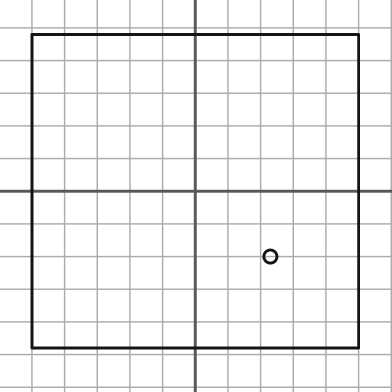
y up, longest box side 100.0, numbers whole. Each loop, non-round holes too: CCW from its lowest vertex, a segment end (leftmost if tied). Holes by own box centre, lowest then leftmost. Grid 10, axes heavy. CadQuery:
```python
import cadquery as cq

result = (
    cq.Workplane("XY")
    .moveTo(-50.0, -48.0)
    .lineTo(50.0, -48.0)
    .lineTo(50.0, 48.0)
    .lineTo(-50.0, 48.0)
    .close()
    .moveTo(23.0, -20.0)
    .circle(2.0)
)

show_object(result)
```